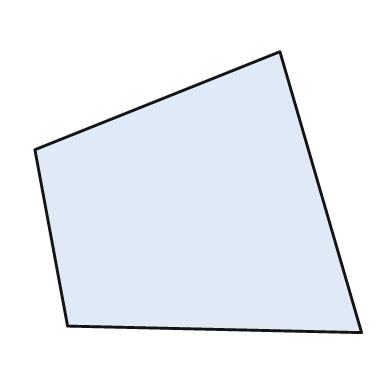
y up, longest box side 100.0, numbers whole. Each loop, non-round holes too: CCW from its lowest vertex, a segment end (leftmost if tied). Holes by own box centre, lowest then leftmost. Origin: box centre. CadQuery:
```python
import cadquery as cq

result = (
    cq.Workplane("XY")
    .moveTo(50.0, -43.0)
    .lineTo(25.0, 43.0)
    .lineTo(-50.0, 13.0)
    .lineTo(-40.0, -41.0)
    .close()
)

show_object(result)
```